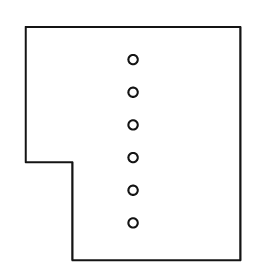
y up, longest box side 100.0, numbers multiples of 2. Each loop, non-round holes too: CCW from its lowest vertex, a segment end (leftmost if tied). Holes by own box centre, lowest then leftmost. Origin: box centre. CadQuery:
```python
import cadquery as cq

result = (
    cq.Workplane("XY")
    .moveTo(-26.0, -50.0)
    .lineTo(46.0, -50.0)
    .lineTo(46.0, 50.0)
    .lineTo(-46.0, 50.0)
    .lineTo(-46.0, -8.0)
    .lineTo(-26.0, -8.0)
    .close()
    .moveTo(0.0, -34.0)
    .circle(2.0)
    .moveTo(0.0, -20.0)
    .circle(2.0)
    .moveTo(0.0, -6.0)
    .circle(2.0)
    .moveTo(0.0, 8.0)
    .circle(2.0)
    .moveTo(0.0, 22.0)
    .circle(2.0)
    .moveTo(0.0, 36.0)
    .circle(2.0)
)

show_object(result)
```